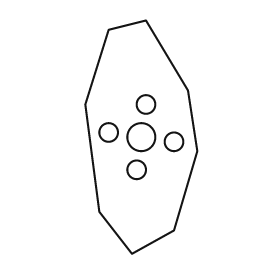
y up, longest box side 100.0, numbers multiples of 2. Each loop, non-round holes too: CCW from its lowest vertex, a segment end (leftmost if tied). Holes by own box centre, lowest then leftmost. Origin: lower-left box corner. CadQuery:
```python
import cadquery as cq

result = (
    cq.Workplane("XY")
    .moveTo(20.0, 0.0)
    .lineTo(38.0, 10.0)
    .lineTo(48.0, 44.0)
    .lineTo(44.0, 70.0)
    .lineTo(26.0, 100.0)
    .lineTo(10.0, 96.0)
    .lineTo(0.0, 64.0)
    .lineTo(6.0, 18.0)
    .close()
    .moveTo(22.0, 36.0)
    .circle(4.0)
    .moveTo(38.0, 48.0)
    .circle(4.0)
    .moveTo(24.0, 50.0)
    .circle(6.0)
    .moveTo(10.0, 52.0)
    .circle(4.0)
    .moveTo(26.0, 64.0)
    .circle(4.0)
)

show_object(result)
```